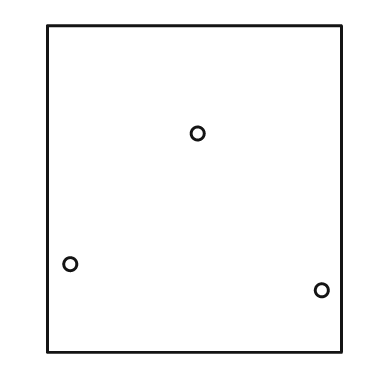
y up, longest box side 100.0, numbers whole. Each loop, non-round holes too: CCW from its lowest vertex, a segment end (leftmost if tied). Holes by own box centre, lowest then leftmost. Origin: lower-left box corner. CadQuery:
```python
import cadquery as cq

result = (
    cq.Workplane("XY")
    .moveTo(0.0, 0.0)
    .lineTo(90.0, 0.0)
    .lineTo(90.0, 100.0)
    .lineTo(0.0, 100.0)
    .close()
    .moveTo(84.0, 19.0)
    .circle(2.0)
    .moveTo(7.0, 27.0)
    .circle(2.0)
    .moveTo(46.0, 67.0)
    .circle(2.0)
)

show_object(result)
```